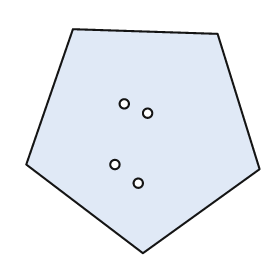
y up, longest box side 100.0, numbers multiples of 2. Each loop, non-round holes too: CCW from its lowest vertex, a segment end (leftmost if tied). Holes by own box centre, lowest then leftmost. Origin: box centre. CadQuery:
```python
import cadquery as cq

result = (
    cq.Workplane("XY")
    .moveTo(0.0, -48.0)
    .lineTo(50.0, -12.0)
    .lineTo(32.0, 46.0)
    .lineTo(-30.0, 48.0)
    .lineTo(-50.0, -10.0)
    .close()
    .moveTo(-2.0, -18.0)
    .circle(2.0)
    .moveTo(-12.0, -10.0)
    .circle(2.0)
    .moveTo(2.0, 12.0)
    .circle(2.0)
    .moveTo(-8.0, 16.0)
    .circle(2.0)
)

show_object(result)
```